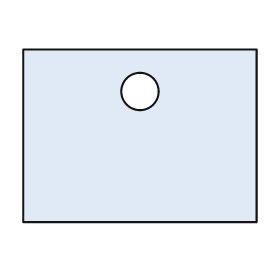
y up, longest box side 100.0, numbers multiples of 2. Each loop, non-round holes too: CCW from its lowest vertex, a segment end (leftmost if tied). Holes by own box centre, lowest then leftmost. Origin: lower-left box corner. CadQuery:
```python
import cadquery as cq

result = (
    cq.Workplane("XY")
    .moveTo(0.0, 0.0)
    .lineTo(100.0, 0.0)
    .lineTo(100.0, 74.0)
    .lineTo(0.0, 74.0)
    .close()
    .moveTo(50.0, 56.0)
    .circle(8.0)
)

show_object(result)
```